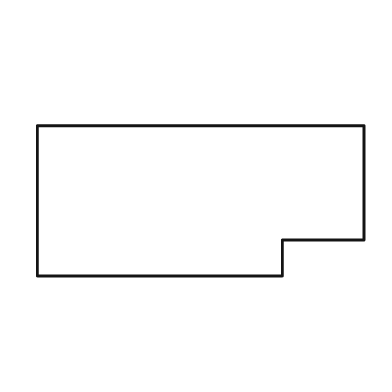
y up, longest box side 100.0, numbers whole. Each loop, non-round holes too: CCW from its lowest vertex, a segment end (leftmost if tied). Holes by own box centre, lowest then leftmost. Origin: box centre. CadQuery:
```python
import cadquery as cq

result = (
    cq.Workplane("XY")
    .moveTo(-50.0, -23.0)
    .lineTo(25.0, -23.0)
    .lineTo(25.0, -12.0)
    .lineTo(50.0, -12.0)
    .lineTo(50.0, 23.0)
    .lineTo(-50.0, 23.0)
    .close()
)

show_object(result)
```